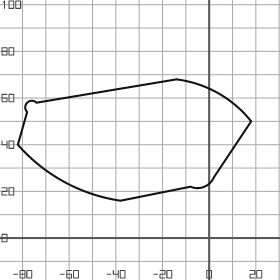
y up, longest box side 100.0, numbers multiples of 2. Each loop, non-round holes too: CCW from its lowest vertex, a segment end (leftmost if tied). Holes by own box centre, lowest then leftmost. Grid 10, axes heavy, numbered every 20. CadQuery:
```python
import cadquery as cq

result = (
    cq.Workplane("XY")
    .moveTo(-38.0, 16.0)
    .lineTo(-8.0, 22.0)
    .threePointArc((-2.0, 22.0), (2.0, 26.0))
    .lineTo(18.0, 50.0)
    .threePointArc((4.0, 62.0), (-14.0, 68.0))
    .lineTo(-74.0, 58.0)
    .threePointArc((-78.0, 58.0), (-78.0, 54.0))
    .lineTo(-82.0, 40.0)
    .threePointArc((-62.0, 24.0), (-38.0, 16.0))
    .close()
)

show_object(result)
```